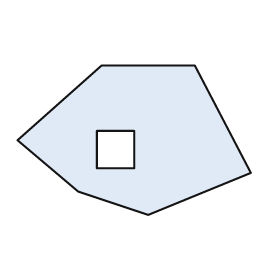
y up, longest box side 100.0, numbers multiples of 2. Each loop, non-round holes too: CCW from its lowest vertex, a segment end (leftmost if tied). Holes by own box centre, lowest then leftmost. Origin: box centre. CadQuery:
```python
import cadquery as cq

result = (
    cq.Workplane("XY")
    .moveTo(6.0, -32.0)
    .lineTo(50.0, -14.0)
    .lineTo(26.0, 32.0)
    .lineTo(-14.0, 32.0)
    .lineTo(-50.0, 0.0)
    .lineTo(-24.0, -22.0)
    .close()
    .moveTo(-16.0, -12.0)
    .lineTo(0.0, -12.0)
    .lineTo(0.0, 4.0)
    .lineTo(-16.0, 4.0)
    .close()
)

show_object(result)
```